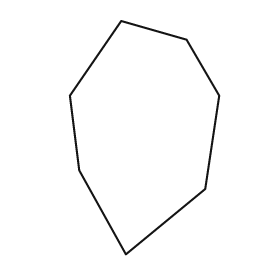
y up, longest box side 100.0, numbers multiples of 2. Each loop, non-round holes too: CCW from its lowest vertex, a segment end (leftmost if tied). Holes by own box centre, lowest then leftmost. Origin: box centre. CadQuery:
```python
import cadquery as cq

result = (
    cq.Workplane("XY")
    .moveTo(-8.0, -50.0)
    .lineTo(26.0, -22.0)
    .lineTo(32.0, 18.0)
    .lineTo(18.0, 42.0)
    .lineTo(-10.0, 50.0)
    .lineTo(-32.0, 18.0)
    .lineTo(-28.0, -14.0)
    .close()
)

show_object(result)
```